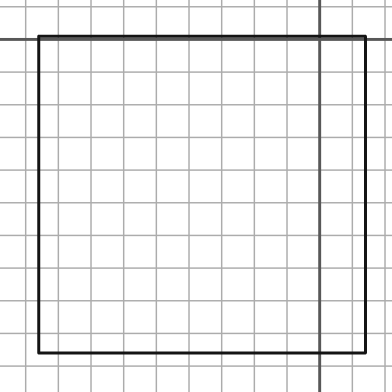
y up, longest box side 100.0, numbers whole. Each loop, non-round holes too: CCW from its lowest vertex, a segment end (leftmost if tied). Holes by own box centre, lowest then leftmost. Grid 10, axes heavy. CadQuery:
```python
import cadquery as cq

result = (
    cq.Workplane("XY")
    .moveTo(-86.0, -96.0)
    .lineTo(14.0, -96.0)
    .lineTo(14.0, 1.0)
    .lineTo(-86.0, 1.0)
    .close()
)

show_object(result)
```